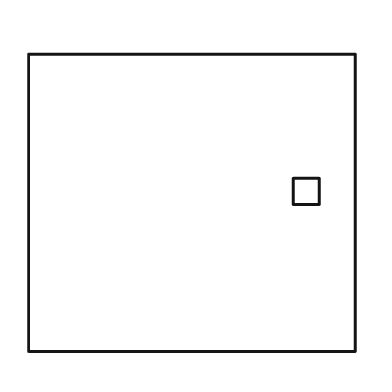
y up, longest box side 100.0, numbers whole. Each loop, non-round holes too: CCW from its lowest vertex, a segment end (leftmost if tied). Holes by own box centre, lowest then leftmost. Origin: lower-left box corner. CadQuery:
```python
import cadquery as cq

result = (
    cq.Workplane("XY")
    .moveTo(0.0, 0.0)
    .lineTo(100.0, 0.0)
    .lineTo(100.0, 91.0)
    .lineTo(0.0, 91.0)
    .close()
    .moveTo(81.0, 45.0)
    .lineTo(89.0, 45.0)
    .lineTo(89.0, 53.0)
    .lineTo(81.0, 53.0)
    .close()
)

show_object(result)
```